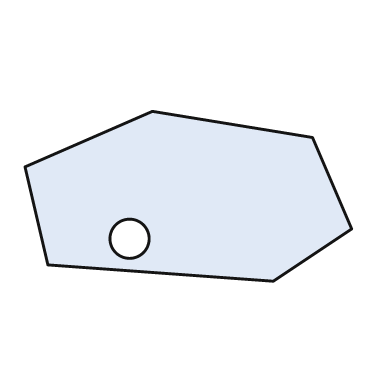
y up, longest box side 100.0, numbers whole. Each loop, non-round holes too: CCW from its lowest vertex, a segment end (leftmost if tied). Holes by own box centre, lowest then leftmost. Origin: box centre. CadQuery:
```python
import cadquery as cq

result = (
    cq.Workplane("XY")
    .moveTo(26.0, -26.0)
    .lineTo(50.0, -10.0)
    .lineTo(38.0, 18.0)
    .lineTo(-11.0, 26.0)
    .lineTo(-50.0, 9.0)
    .lineTo(-43.0, -21.0)
    .close()
    .moveTo(-18.0, -13.0)
    .circle(6.0)
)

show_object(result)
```